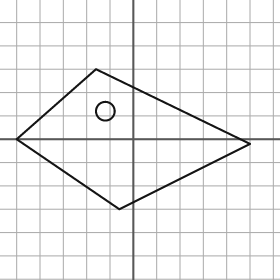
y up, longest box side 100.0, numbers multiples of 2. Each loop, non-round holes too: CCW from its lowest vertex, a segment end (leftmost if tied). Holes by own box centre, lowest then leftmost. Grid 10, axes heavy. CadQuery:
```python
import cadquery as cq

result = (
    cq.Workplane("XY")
    .moveTo(-6.0, -30.0)
    .lineTo(50.0, -2.0)
    .lineTo(-16.0, 30.0)
    .lineTo(-50.0, 0.0)
    .close()
    .moveTo(-12.0, 12.0)
    .circle(4.0)
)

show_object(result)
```